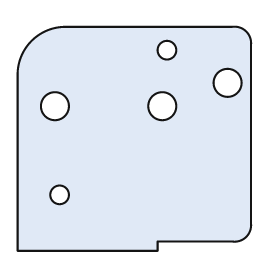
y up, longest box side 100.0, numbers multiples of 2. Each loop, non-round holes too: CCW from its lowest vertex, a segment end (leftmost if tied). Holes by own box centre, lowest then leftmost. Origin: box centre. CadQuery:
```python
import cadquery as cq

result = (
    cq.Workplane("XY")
    .moveTo(-50.0, -48.0)
    .lineTo(10.0, -48.0)
    .lineTo(10.0, -44.0)
    .lineTo(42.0, -44.0)
    .threePointArc((48.0, -42.0), (50.0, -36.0))
    .lineTo(50.0, 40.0)
    .threePointArc((48.0, 46.0), (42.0, 48.0))
    .lineTo(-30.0, 48.0)
    .threePointArc((-44.0, 42.0), (-50.0, 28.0))
    .close()
    .moveTo(-32.0, -24.0)
    .circle(4.0)
    .moveTo(-34.0, 14.0)
    .circle(6.0)
    .moveTo(12.0, 14.0)
    .circle(6.0)
    .moveTo(40.0, 24.0)
    .circle(6.0)
    .moveTo(14.0, 38.0)
    .circle(4.0)
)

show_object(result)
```